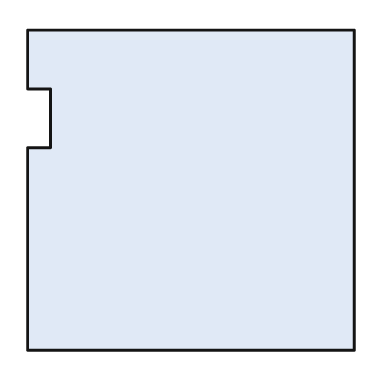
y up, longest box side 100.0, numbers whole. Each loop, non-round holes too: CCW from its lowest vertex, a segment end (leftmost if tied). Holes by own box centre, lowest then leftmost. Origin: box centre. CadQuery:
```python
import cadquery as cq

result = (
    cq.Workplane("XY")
    .moveTo(-50.0, -49.0)
    .lineTo(50.0, -49.0)
    .lineTo(50.0, 49.0)
    .lineTo(-50.0, 49.0)
    .lineTo(-50.0, 31.0)
    .lineTo(-43.0, 31.0)
    .lineTo(-43.0, 13.0)
    .lineTo(-50.0, 13.0)
    .close()
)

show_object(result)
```